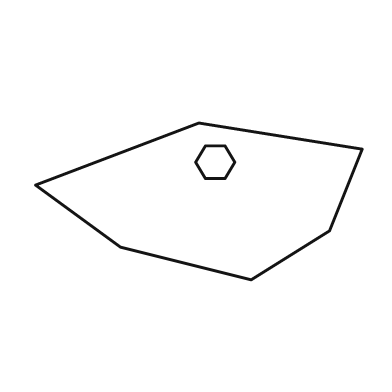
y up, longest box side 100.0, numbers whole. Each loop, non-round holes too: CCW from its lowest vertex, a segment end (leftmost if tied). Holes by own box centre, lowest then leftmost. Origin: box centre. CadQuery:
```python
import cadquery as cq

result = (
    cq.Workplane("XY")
    .moveTo(16.0, -24.0)
    .lineTo(40.0, -9.0)
    .lineTo(50.0, 16.0)
    .lineTo(0.0, 24.0)
    .lineTo(-50.0, 5.0)
    .lineTo(-24.0, -14.0)
    .close()
    .moveTo(2.0, 7.0)
    .lineTo(8.0, 7.0)
    .lineTo(11.0, 12.0)
    .lineTo(8.0, 17.0)
    .lineTo(2.0, 17.0)
    .lineTo(-1.0, 12.0)
    .close()
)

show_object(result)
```